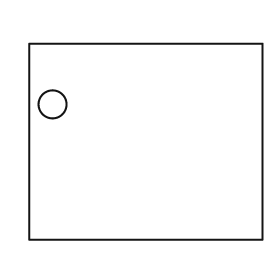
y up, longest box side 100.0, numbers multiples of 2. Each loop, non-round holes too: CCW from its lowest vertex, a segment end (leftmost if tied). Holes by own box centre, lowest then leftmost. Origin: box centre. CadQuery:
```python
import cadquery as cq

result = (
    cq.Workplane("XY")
    .moveTo(-50.0, -42.0)
    .lineTo(50.0, -42.0)
    .lineTo(50.0, 42.0)
    .lineTo(-50.0, 42.0)
    .close()
    .moveTo(-40.0, 16.0)
    .circle(6.0)
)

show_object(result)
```